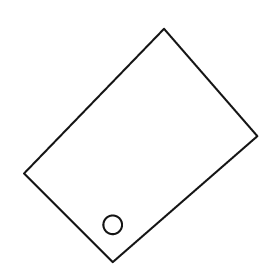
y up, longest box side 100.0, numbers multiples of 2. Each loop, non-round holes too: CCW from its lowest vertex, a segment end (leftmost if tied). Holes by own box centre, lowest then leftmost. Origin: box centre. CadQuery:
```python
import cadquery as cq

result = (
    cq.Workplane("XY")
    .moveTo(-12.0, -50.0)
    .lineTo(50.0, 4.0)
    .lineTo(10.0, 50.0)
    .lineTo(-50.0, -12.0)
    .close()
    .moveTo(-12.0, -34.0)
    .circle(4.0)
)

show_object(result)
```